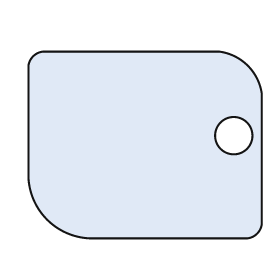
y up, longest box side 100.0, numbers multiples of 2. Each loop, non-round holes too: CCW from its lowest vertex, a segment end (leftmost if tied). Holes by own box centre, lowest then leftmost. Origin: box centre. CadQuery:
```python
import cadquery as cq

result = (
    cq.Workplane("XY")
    .moveTo(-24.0, -40.0)
    .lineTo(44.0, -40.0)
    .threePointArc((48.0, -38.0), (50.0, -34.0))
    .lineTo(50.0, 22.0)
    .threePointArc((44.0, 34.0), (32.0, 40.0))
    .lineTo(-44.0, 40.0)
    .threePointArc((-48.0, 38.0), (-50.0, 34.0))
    .lineTo(-50.0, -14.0)
    .threePointArc((-42.0, -32.0), (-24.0, -40.0))
    .close()
    .moveTo(38.0, 4.0)
    .circle(8.0)
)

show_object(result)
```